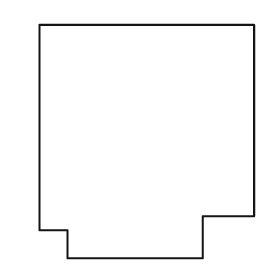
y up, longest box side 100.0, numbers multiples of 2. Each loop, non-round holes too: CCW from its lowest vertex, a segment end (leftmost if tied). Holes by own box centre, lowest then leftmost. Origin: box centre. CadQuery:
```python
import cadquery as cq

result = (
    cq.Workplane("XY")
    .moveTo(-34.0, -50.0)
    .lineTo(24.0, -50.0)
    .lineTo(24.0, -32.0)
    .lineTo(46.0, -32.0)
    .lineTo(46.0, 50.0)
    .lineTo(-46.0, 50.0)
    .lineTo(-46.0, -38.0)
    .lineTo(-34.0, -38.0)
    .close()
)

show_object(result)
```